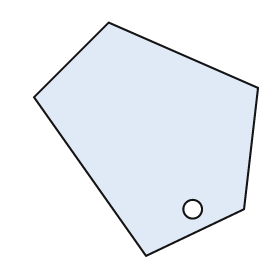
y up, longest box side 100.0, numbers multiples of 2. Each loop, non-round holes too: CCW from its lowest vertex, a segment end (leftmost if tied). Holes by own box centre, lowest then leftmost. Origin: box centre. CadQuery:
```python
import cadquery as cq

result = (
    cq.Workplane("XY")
    .moveTo(0.0, -50.0)
    .lineTo(42.0, -30.0)
    .lineTo(48.0, 22.0)
    .lineTo(-16.0, 50.0)
    .lineTo(-48.0, 18.0)
    .close()
    .moveTo(20.0, -30.0)
    .circle(4.0)
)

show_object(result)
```